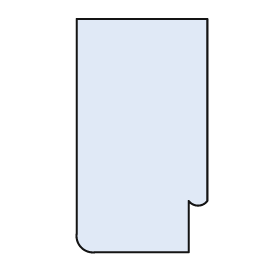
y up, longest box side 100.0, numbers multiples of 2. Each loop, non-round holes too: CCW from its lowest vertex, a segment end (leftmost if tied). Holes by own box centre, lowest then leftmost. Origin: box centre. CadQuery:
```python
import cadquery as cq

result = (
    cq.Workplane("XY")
    .moveTo(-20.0, -50.0)
    .lineTo(20.0, -50.0)
    .lineTo(20.0, -28.0)
    .threePointArc((24.0, -30.0), (28.0, -28.0))
    .lineTo(28.0, 50.0)
    .lineTo(-28.0, 50.0)
    .lineTo(-28.0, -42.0)
    .threePointArc((-26.0, -48.0), (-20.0, -50.0))
    .close()
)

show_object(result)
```